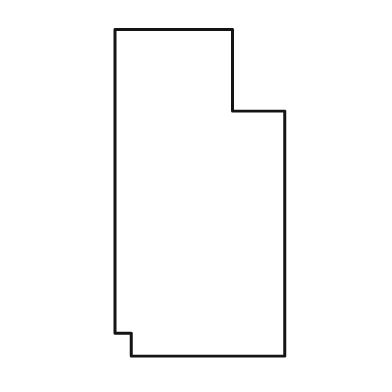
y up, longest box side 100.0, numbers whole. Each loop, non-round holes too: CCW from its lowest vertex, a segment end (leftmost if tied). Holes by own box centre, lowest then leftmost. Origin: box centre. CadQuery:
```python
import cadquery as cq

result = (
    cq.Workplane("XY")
    .moveTo(-21.0, -50.0)
    .lineTo(26.0, -50.0)
    .lineTo(26.0, 25.0)
    .lineTo(10.0, 25.0)
    .lineTo(10.0, 50.0)
    .lineTo(-26.0, 50.0)
    .lineTo(-26.0, -43.0)
    .lineTo(-21.0, -43.0)
    .close()
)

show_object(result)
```